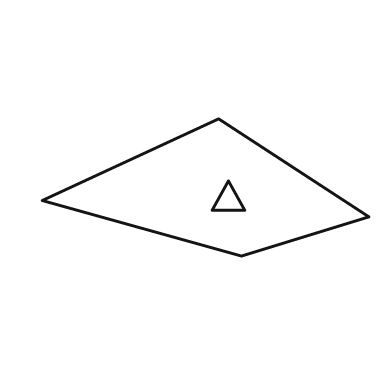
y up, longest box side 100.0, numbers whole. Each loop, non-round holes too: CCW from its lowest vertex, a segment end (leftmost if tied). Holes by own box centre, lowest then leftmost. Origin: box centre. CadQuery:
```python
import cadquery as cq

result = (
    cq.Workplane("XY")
    .moveTo(11.0, -21.0)
    .lineTo(50.0, -9.0)
    .lineTo(4.0, 21.0)
    .lineTo(-50.0, -4.0)
    .close()
    .moveTo(2.0, -7.0)
    .lineTo(12.0, -7.0)
    .lineTo(7.0, 2.0)
    .close()
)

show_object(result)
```